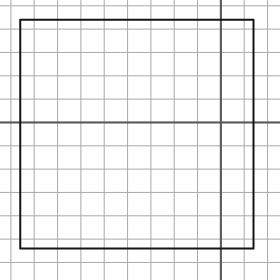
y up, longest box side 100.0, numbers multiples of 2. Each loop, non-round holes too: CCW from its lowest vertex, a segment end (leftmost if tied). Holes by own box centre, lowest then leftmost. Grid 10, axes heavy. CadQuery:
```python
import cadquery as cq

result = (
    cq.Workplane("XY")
    .moveTo(-86.0, -54.0)
    .lineTo(14.0, -54.0)
    .lineTo(14.0, 44.0)
    .lineTo(-86.0, 44.0)
    .close()
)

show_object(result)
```